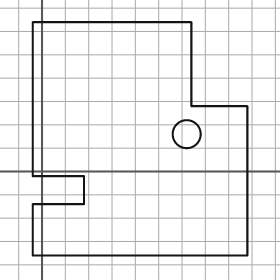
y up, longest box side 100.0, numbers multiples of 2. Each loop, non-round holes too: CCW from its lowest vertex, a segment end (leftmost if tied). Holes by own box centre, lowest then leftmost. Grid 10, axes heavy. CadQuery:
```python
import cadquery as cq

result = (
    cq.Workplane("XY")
    .moveTo(-4.0, -36.0)
    .lineTo(88.0, -36.0)
    .lineTo(88.0, 28.0)
    .lineTo(64.0, 28.0)
    .lineTo(64.0, 64.0)
    .lineTo(-4.0, 64.0)
    .lineTo(-4.0, -2.0)
    .lineTo(18.0, -2.0)
    .lineTo(18.0, -14.0)
    .lineTo(-4.0, -14.0)
    .close()
    .moveTo(62.0, 16.0)
    .circle(6.0)
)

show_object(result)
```